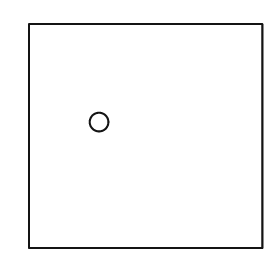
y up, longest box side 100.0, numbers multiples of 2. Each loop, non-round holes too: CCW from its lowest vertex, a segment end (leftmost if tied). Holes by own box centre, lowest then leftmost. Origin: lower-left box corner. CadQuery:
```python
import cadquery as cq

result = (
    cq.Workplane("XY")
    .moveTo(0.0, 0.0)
    .lineTo(100.0, 0.0)
    .lineTo(100.0, 96.0)
    .lineTo(0.0, 96.0)
    .close()
    .moveTo(30.0, 54.0)
    .circle(4.0)
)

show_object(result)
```